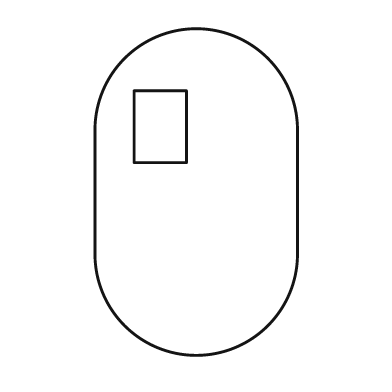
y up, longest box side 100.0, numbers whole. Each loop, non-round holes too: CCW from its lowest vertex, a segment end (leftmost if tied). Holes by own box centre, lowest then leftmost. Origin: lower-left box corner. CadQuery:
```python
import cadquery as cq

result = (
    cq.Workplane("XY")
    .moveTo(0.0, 31.0)
    .threePointArc((31.0, 0.0), (62.0, 31.0))
    .lineTo(62.0, 69.0)
    .threePointArc((31.0, 100.0), (0.0, 69.0))
    .close()
    .moveTo(12.0, 59.0)
    .lineTo(28.0, 59.0)
    .lineTo(28.0, 81.0)
    .lineTo(12.0, 81.0)
    .close()
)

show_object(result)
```